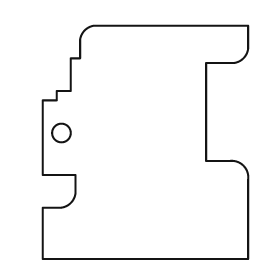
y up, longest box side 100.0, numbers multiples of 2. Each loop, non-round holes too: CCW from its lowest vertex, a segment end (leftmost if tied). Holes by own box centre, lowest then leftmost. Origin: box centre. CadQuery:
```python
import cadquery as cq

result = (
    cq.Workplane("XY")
    .moveTo(-44.0, -50.0)
    .lineTo(44.0, -50.0)
    .lineTo(44.0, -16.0)
    .threePointArc((42.0, -10.0), (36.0, -8.0))
    .lineTo(26.0, -8.0)
    .lineTo(26.0, 34.0)
    .lineTo(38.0, 34.0)
    .threePointArc((42.0, 36.0), (44.0, 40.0))
    .lineTo(44.0, 50.0)
    .lineTo(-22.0, 50.0)
    .threePointArc((-26.0, 48.0), (-28.0, 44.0))
    .lineTo(-28.0, 36.0)
    .lineTo(-32.0, 36.0)
    .lineTo(-32.0, 22.0)
    .lineTo(-38.0, 22.0)
    .lineTo(-38.0, 18.0)
    .lineTo(-44.0, 18.0)
    .lineTo(-44.0, -14.0)
    .lineTo(-30.0, -14.0)
    .lineTo(-30.0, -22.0)
    .threePointArc((-32.0, -26.0), (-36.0, -28.0))
    .lineTo(-44.0, -28.0)
    .close()
    .moveTo(-36.0, 4.0)
    .circle(4.0)
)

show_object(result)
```